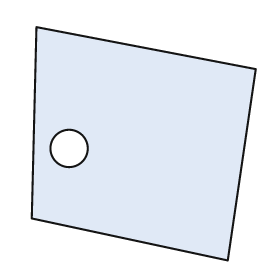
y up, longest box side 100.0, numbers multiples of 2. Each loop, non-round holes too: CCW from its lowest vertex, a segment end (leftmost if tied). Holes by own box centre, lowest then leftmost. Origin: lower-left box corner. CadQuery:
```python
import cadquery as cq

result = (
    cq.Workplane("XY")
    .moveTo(84.0, 0.0)
    .lineTo(96.0, 82.0)
    .lineTo(2.0, 100.0)
    .lineTo(0.0, 18.0)
    .close()
    .moveTo(16.0, 48.0)
    .circle(8.0)
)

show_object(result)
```